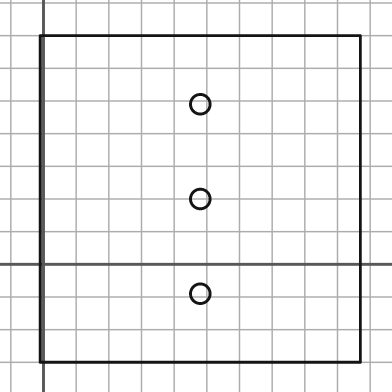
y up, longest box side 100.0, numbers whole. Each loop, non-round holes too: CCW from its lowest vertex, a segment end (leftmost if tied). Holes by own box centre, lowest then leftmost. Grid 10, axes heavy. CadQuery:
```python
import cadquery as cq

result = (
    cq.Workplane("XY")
    .moveTo(-1.0, -30.0)
    .lineTo(97.0, -30.0)
    .lineTo(97.0, 70.0)
    .lineTo(-1.0, 70.0)
    .close()
    .moveTo(48.0, -9.0)
    .circle(3.0)
    .moveTo(48.0, 20.0)
    .circle(3.0)
    .moveTo(48.0, 49.0)
    .circle(3.0)
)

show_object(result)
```